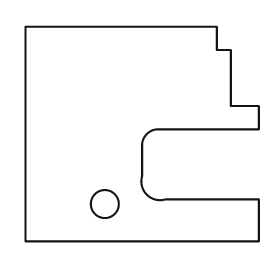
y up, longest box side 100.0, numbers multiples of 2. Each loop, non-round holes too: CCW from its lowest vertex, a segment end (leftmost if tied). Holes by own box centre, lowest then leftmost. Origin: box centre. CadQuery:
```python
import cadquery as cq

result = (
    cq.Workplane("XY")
    .moveTo(-50.0, -46.0)
    .lineTo(50.0, -46.0)
    .lineTo(50.0, -28.0)
    .lineTo(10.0, -28.0)
    .threePointArc((2.0, -26.0), (0.0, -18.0))
    .lineTo(0.0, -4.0)
    .threePointArc((2.0, 0.0), (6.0, 2.0))
    .lineTo(50.0, 2.0)
    .lineTo(50.0, 12.0)
    .lineTo(38.0, 12.0)
    .lineTo(38.0, 36.0)
    .lineTo(32.0, 36.0)
    .lineTo(32.0, 46.0)
    .lineTo(-50.0, 46.0)
    .close()
    .moveTo(-16.0, -30.0)
    .circle(6.0)
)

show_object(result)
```